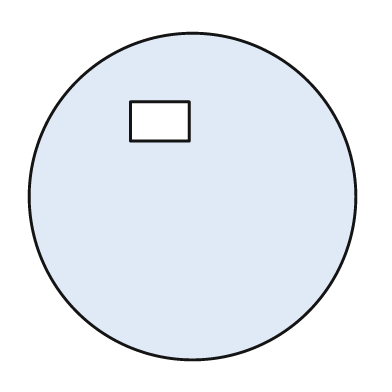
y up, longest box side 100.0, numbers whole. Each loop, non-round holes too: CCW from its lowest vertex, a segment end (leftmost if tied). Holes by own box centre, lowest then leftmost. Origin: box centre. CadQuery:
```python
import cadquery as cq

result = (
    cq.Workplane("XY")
    .moveTo(0.0, 0.0)
    .circle(50.0)
    .moveTo(-19.0, 17.0)
    .lineTo(-1.0, 17.0)
    .lineTo(-1.0, 29.0)
    .lineTo(-19.0, 29.0)
    .close()
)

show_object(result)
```